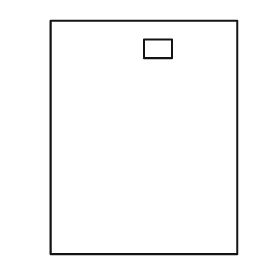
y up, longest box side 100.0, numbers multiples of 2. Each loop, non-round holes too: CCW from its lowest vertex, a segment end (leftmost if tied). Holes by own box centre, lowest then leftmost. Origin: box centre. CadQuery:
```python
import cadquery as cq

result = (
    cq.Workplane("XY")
    .moveTo(-40.0, -50.0)
    .lineTo(40.0, -50.0)
    .lineTo(40.0, 50.0)
    .lineTo(-40.0, 50.0)
    .close()
    .moveTo(0.0, 34.0)
    .lineTo(12.0, 34.0)
    .lineTo(12.0, 42.0)
    .lineTo(0.0, 42.0)
    .close()
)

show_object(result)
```